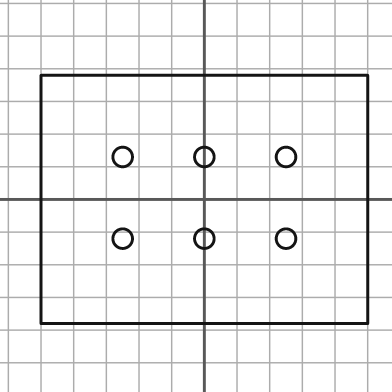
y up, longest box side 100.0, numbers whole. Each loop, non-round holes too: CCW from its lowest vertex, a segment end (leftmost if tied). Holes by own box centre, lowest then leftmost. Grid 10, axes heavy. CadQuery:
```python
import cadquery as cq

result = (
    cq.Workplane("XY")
    .moveTo(-50.0, -38.0)
    .lineTo(50.0, -38.0)
    .lineTo(50.0, 38.0)
    .lineTo(-50.0, 38.0)
    .close()
    .moveTo(-25.0, -12.0)
    .circle(3.0)
    .moveTo(0.0, -12.0)
    .circle(3.0)
    .moveTo(25.0, -12.0)
    .circle(3.0)
    .moveTo(-25.0, 13.0)
    .circle(3.0)
    .moveTo(0.0, 13.0)
    .circle(3.0)
    .moveTo(25.0, 13.0)
    .circle(3.0)
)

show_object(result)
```